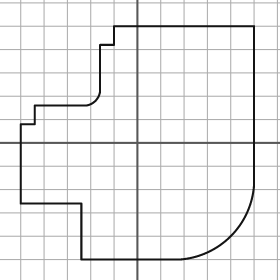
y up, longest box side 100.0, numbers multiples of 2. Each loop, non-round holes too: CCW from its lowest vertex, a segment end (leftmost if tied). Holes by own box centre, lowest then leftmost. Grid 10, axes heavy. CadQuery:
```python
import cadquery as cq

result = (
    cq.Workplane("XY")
    .moveTo(-24.0, -50.0)
    .lineTo(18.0, -50.0)
    .threePointArc((40.0, -40.0), (50.0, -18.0))
    .lineTo(50.0, 50.0)
    .lineTo(-10.0, 50.0)
    .lineTo(-10.0, 42.0)
    .lineTo(-16.0, 42.0)
    .lineTo(-16.0, 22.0)
    .threePointArc((-18.0, 18.0), (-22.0, 16.0))
    .lineTo(-44.0, 16.0)
    .lineTo(-44.0, 8.0)
    .lineTo(-50.0, 8.0)
    .lineTo(-50.0, -26.0)
    .lineTo(-24.0, -26.0)
    .close()
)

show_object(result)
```